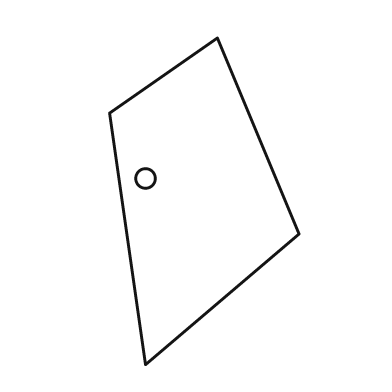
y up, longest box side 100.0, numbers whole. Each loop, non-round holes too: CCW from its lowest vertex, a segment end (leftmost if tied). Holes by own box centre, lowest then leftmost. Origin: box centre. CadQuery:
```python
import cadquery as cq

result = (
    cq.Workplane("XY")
    .moveTo(-18.0, -50.0)
    .lineTo(29.0, -10.0)
    .lineTo(4.0, 50.0)
    .lineTo(-29.0, 27.0)
    .close()
    .moveTo(-18.0, 7.0)
    .circle(3.0)
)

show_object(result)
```